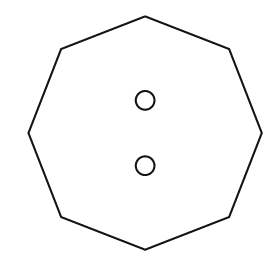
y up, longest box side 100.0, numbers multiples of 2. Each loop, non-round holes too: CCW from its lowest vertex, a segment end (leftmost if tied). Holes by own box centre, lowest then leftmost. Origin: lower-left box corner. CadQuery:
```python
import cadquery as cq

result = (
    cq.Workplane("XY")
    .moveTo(50.0, 0.0)
    .lineTo(86.0, 14.0)
    .lineTo(100.0, 50.0)
    .lineTo(86.0, 86.0)
    .lineTo(50.0, 100.0)
    .lineTo(14.0, 86.0)
    .lineTo(0.0, 50.0)
    .lineTo(14.0, 14.0)
    .close()
    .moveTo(50.0, 36.0)
    .circle(4.0)
    .moveTo(50.0, 64.0)
    .circle(4.0)
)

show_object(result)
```